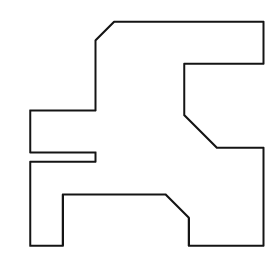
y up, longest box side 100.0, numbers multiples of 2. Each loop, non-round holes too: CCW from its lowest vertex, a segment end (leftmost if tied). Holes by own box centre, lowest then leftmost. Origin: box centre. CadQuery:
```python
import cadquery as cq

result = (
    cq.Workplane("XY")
    .moveTo(-50.0, -48.0)
    .lineTo(-36.0, -48.0)
    .lineTo(-36.0, -26.0)
    .lineTo(8.0, -26.0)
    .lineTo(18.0, -36.0)
    .lineTo(18.0, -48.0)
    .lineTo(50.0, -48.0)
    .lineTo(50.0, -6.0)
    .lineTo(30.0, -6.0)
    .lineTo(16.0, 8.0)
    .lineTo(16.0, 30.0)
    .lineTo(50.0, 30.0)
    .lineTo(50.0, 48.0)
    .lineTo(-14.0, 48.0)
    .lineTo(-22.0, 40.0)
    .lineTo(-22.0, 10.0)
    .lineTo(-50.0, 10.0)
    .lineTo(-50.0, -8.0)
    .lineTo(-22.0, -8.0)
    .lineTo(-22.0, -12.0)
    .lineTo(-50.0, -12.0)
    .close()
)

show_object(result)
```